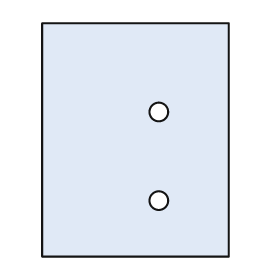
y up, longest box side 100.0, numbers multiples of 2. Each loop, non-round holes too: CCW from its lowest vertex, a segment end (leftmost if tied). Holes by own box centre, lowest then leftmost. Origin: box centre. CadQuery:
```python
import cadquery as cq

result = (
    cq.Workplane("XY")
    .moveTo(-40.0, -50.0)
    .lineTo(40.0, -50.0)
    .lineTo(40.0, 50.0)
    .lineTo(-40.0, 50.0)
    .close()
    .moveTo(10.0, -26.0)
    .circle(4.0)
    .moveTo(10.0, 12.0)
    .circle(4.0)
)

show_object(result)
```